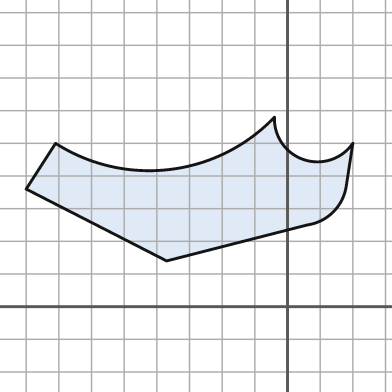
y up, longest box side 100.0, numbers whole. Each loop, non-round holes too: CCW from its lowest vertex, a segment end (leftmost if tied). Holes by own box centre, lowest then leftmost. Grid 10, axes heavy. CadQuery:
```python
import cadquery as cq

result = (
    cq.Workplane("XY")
    .moveTo(-37.0, 14.0)
    .lineTo(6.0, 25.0)
    .threePointArc((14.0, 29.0), (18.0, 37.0))
    .lineTo(20.0, 50.0)
    .threePointArc((5.0, 45.0), (-4.0, 58.0))
    .threePointArc((-36.0, 42.0), (-71.0, 50.0))
    .lineTo(-80.0, 36.0)
    .close()
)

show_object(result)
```